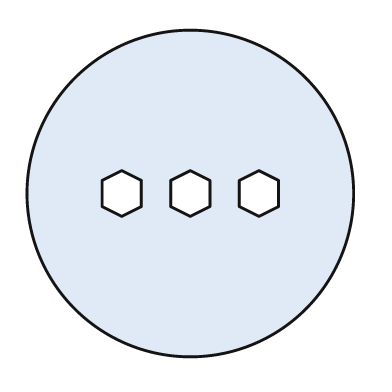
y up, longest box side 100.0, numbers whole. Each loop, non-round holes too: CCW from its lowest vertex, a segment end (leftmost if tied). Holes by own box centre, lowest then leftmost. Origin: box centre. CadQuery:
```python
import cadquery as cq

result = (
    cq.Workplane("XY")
    .moveTo(0.0, 0.0)
    .circle(50.0)
    .moveTo(-21.0, -7.0)
    .lineTo(-15.0, -4.0)
    .lineTo(-15.0, 4.0)
    .lineTo(-21.0, 7.0)
    .lineTo(-27.0, 4.0)
    .lineTo(-27.0, -4.0)
    .close()
    .moveTo(0.0, -7.0)
    .lineTo(6.0, -4.0)
    .lineTo(6.0, 4.0)
    .lineTo(0.0, 7.0)
    .lineTo(-6.0, 4.0)
    .lineTo(-6.0, -4.0)
    .close()
    .moveTo(21.0, -7.0)
    .lineTo(27.0, -4.0)
    .lineTo(27.0, 4.0)
    .lineTo(21.0, 7.0)
    .lineTo(15.0, 4.0)
    .lineTo(15.0, -4.0)
    .close()
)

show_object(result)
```